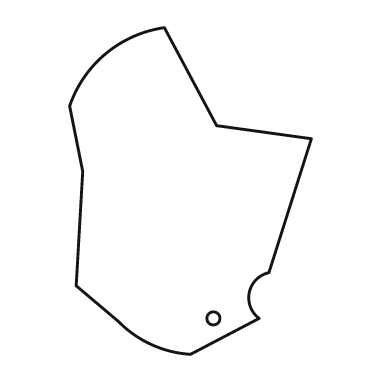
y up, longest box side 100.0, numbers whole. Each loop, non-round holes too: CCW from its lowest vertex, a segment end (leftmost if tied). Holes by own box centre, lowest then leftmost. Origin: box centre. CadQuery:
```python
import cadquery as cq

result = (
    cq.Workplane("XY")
    .moveTo(0.0, -50.0)
    .lineTo(21.0, -39.0)
    .threePointArc((18.0, -31.0), (24.0, -25.0))
    .lineTo(37.0, 16.0)
    .lineTo(8.0, 20.0)
    .lineTo(-8.0, 50.0)
    .threePointArc((-26.0, 42.0), (-37.0, 26.0))
    .lineTo(-33.0, 6.0)
    .lineTo(-35.0, -29.0)
    .lineTo(-22.0, -40.0)
    .threePointArc((-12.0, -47.0), (0.0, -50.0))
    .close()
    .moveTo(7.0, -39.0)
    .circle(2.0)
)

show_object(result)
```